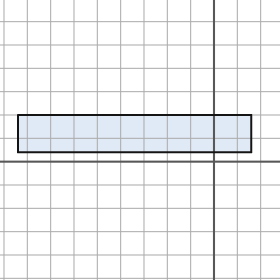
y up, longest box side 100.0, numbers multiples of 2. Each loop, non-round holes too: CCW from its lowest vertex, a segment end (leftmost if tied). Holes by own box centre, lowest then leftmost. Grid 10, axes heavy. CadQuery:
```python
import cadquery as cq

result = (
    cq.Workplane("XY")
    .moveTo(-84.0, 4.0)
    .lineTo(16.0, 4.0)
    .lineTo(16.0, 20.0)
    .lineTo(-84.0, 20.0)
    .close()
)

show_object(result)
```